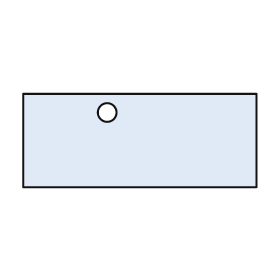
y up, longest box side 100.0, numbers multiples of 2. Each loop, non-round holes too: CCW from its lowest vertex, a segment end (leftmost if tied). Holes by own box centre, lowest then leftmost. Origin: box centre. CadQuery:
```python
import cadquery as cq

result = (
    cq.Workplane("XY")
    .moveTo(-50.0, -20.0)
    .lineTo(50.0, -20.0)
    .lineTo(50.0, 20.0)
    .lineTo(-50.0, 20.0)
    .close()
    .moveTo(-14.0, 12.0)
    .circle(4.0)
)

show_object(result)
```